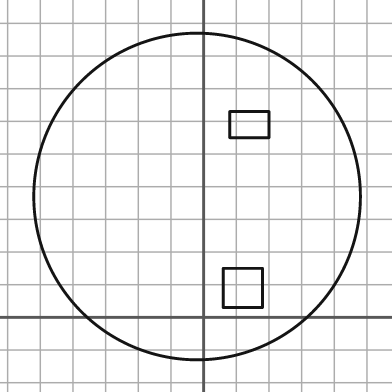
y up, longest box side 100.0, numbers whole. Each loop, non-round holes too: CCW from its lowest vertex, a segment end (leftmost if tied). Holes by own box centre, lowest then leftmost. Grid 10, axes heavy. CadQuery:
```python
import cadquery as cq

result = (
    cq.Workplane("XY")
    .moveTo(-2.0, 37.0)
    .circle(50.0)
    .moveTo(6.0, 3.0)
    .lineTo(18.0, 3.0)
    .lineTo(18.0, 15.0)
    .lineTo(6.0, 15.0)
    .close()
    .moveTo(8.0, 55.0)
    .lineTo(20.0, 55.0)
    .lineTo(20.0, 63.0)
    .lineTo(8.0, 63.0)
    .close()
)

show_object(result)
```